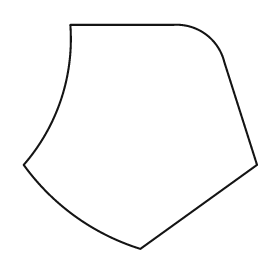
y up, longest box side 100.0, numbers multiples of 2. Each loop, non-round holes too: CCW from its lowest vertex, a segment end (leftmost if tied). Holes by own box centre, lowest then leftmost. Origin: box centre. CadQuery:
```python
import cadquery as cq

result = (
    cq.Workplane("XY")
    .moveTo(0.0, -48.0)
    .lineTo(50.0, -12.0)
    .lineTo(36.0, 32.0)
    .threePointArc((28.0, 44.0), (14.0, 48.0))
    .lineTo(-30.0, 48.0)
    .threePointArc((-34.0, 16.0), (-50.0, -12.0))
    .threePointArc((-28.0, -34.0), (0.0, -48.0))
    .close()
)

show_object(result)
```